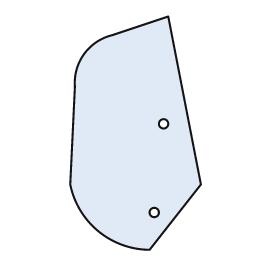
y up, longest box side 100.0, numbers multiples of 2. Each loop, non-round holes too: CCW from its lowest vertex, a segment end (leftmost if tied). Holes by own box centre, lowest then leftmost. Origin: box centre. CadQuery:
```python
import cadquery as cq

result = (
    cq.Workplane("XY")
    .moveTo(6.0, -50.0)
    .lineTo(28.0, -22.0)
    .lineTo(14.0, 50.0)
    .lineTo(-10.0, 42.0)
    .threePointArc((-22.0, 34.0), (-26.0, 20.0))
    .lineTo(-28.0, -22.0)
    .threePointArc((-16.0, -42.0), (6.0, -50.0))
    .close()
    .moveTo(8.0, -34.0)
    .circle(2.0)
    .moveTo(12.0, 4.0)
    .circle(2.0)
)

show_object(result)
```